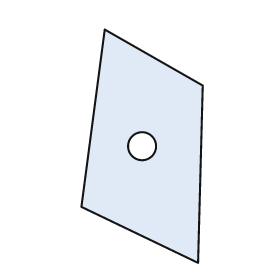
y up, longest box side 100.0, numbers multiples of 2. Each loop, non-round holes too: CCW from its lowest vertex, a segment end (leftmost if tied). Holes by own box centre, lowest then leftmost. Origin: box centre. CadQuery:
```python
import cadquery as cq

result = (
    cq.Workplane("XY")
    .moveTo(24.0, -50.0)
    .lineTo(26.0, 26.0)
    .lineTo(-16.0, 50.0)
    .lineTo(-26.0, -26.0)
    .close()
    .moveTo(0.0, 0.0)
    .circle(6.0)
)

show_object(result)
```